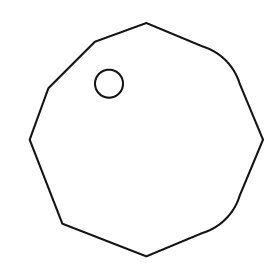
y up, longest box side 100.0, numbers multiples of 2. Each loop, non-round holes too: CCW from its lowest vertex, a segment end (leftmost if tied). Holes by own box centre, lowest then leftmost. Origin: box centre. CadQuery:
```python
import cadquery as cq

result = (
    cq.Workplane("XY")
    .moveTo(0.0, -50.0)
    .lineTo(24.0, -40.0)
    .threePointArc((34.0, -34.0), (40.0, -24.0))
    .lineTo(50.0, 0.0)
    .lineTo(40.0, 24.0)
    .threePointArc((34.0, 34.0), (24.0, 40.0))
    .lineTo(0.0, 50.0)
    .lineTo(-22.0, 42.0)
    .lineTo(-42.0, 22.0)
    .lineTo(-50.0, 0.0)
    .lineTo(-36.0, -36.0)
    .close()
    .moveTo(-16.0, 24.0)
    .circle(6.0)
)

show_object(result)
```